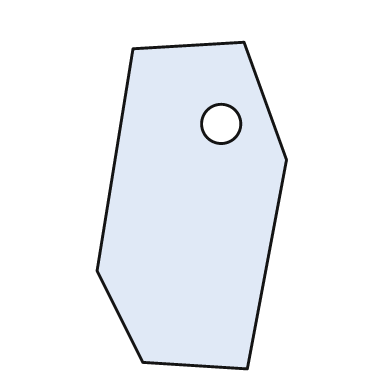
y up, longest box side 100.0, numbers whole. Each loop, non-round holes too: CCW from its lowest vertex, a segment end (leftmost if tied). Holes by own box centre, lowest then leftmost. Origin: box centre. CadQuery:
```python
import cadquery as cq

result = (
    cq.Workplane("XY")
    .moveTo(17.0, -50.0)
    .lineTo(29.0, 14.0)
    .lineTo(16.0, 50.0)
    .lineTo(-18.0, 48.0)
    .lineTo(-29.0, -20.0)
    .lineTo(-15.0, -48.0)
    .close()
    .moveTo(9.0, 25.0)
    .circle(6.0)
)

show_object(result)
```